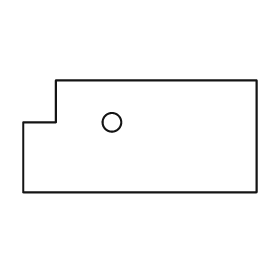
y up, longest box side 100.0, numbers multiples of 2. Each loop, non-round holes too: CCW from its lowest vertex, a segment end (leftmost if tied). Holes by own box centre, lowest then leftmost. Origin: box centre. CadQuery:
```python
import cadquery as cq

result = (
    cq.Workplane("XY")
    .moveTo(-50.0, -24.0)
    .lineTo(50.0, -24.0)
    .lineTo(50.0, 24.0)
    .lineTo(-36.0, 24.0)
    .lineTo(-36.0, 6.0)
    .lineTo(-50.0, 6.0)
    .close()
    .moveTo(-12.0, 6.0)
    .circle(4.0)
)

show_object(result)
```